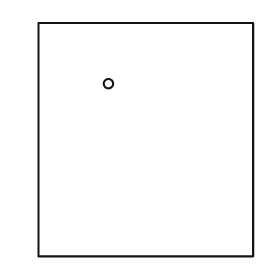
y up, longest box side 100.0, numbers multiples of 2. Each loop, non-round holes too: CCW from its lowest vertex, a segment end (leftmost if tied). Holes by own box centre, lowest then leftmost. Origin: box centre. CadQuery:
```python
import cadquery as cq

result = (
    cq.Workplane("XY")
    .moveTo(-46.0, -50.0)
    .lineTo(46.0, -50.0)
    .lineTo(46.0, 50.0)
    .lineTo(-46.0, 50.0)
    .close()
    .moveTo(-16.0, 24.0)
    .circle(2.0)
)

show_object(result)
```